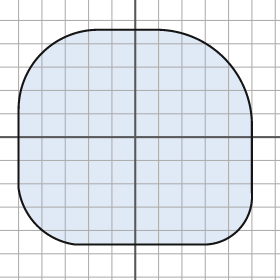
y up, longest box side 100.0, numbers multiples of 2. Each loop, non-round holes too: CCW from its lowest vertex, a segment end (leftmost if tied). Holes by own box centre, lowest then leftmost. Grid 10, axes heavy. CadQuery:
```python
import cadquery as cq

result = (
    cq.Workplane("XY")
    .moveTo(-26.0, -46.0)
    .lineTo(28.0, -46.0)
    .threePointArc((44.0, -40.0), (50.0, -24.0))
    .lineTo(50.0, 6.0)
    .threePointArc((38.0, 34.0), (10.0, 46.0))
    .lineTo(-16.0, 46.0)
    .threePointArc((-40.0, 36.0), (-50.0, 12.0))
    .lineTo(-50.0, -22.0)
    .threePointArc((-42.0, -38.0), (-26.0, -46.0))
    .close()
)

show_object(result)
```